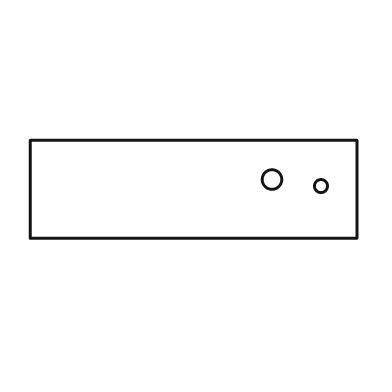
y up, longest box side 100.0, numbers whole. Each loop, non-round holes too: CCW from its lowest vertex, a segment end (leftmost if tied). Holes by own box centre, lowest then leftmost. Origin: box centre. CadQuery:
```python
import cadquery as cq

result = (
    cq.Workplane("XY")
    .moveTo(-50.0, -15.0)
    .lineTo(50.0, -15.0)
    .lineTo(50.0, 15.0)
    .lineTo(-50.0, 15.0)
    .close()
    .moveTo(39.0, 1.0)
    .circle(2.0)
    .moveTo(24.0, 3.0)
    .circle(3.0)
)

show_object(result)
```